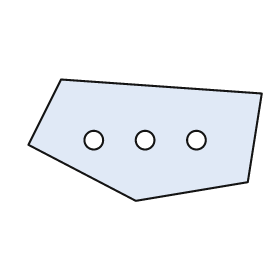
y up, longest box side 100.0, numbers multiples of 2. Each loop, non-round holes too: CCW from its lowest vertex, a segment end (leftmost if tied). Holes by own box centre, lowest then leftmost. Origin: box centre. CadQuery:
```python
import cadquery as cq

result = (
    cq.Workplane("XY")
    .moveTo(-4.0, -26.0)
    .lineTo(44.0, -18.0)
    .lineTo(50.0, 20.0)
    .lineTo(-36.0, 26.0)
    .lineTo(-50.0, -2.0)
    .close()
    .moveTo(-22.0, 0.0)
    .circle(4.0)
    .moveTo(0.0, 0.0)
    .circle(4.0)
    .moveTo(22.0, 0.0)
    .circle(4.0)
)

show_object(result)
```